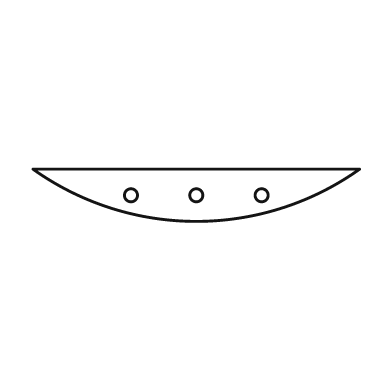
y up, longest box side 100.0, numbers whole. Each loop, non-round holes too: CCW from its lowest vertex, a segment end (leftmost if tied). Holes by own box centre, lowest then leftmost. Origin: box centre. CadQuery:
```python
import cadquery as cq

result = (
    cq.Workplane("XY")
    .moveTo(-50.0, 8.0)
    .threePointArc((0.0, -8.0), (50.0, 8.0))
    .close()
    .moveTo(-20.0, 0.0)
    .circle(2.0)
    .moveTo(0.0, 0.0)
    .circle(2.0)
    .moveTo(20.0, 0.0)
    .circle(2.0)
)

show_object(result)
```